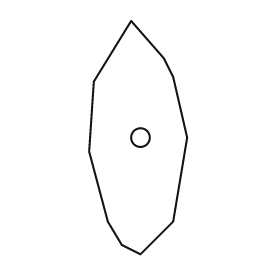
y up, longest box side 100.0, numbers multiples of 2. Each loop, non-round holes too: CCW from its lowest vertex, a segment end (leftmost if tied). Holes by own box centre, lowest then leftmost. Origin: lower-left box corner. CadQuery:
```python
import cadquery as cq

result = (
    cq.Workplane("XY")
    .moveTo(22.0, 0.0)
    .lineTo(36.0, 14.0)
    .lineTo(42.0, 50.0)
    .lineTo(36.0, 76.0)
    .lineTo(32.0, 84.0)
    .lineTo(18.0, 100.0)
    .lineTo(2.0, 74.0)
    .lineTo(0.0, 44.0)
    .lineTo(8.0, 14.0)
    .lineTo(14.0, 4.0)
    .close()
    .moveTo(22.0, 50.0)
    .circle(4.0)
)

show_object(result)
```